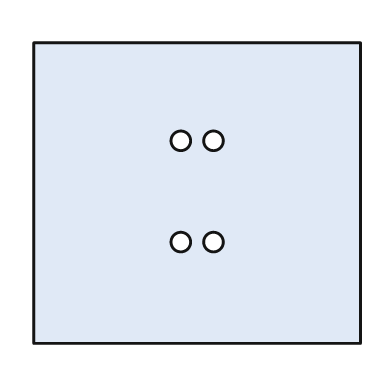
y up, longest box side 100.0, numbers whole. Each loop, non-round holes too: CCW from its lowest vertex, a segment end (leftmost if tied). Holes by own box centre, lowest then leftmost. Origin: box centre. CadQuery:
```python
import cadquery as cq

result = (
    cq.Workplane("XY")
    .moveTo(-50.0, -46.0)
    .lineTo(50.0, -46.0)
    .lineTo(50.0, 46.0)
    .lineTo(-50.0, 46.0)
    .close()
    .moveTo(-5.0, -15.0)
    .circle(3.0)
    .moveTo(5.0, -15.0)
    .circle(3.0)
    .moveTo(-5.0, 16.0)
    .circle(3.0)
    .moveTo(5.0, 16.0)
    .circle(3.0)
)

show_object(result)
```